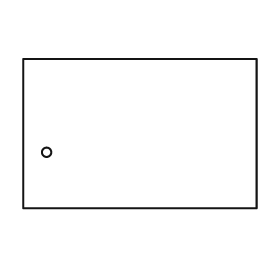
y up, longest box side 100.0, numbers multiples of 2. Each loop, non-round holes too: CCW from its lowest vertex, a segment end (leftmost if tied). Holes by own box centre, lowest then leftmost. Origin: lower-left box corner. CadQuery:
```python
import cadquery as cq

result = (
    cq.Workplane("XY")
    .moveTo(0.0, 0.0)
    .lineTo(100.0, 0.0)
    .lineTo(100.0, 64.0)
    .lineTo(0.0, 64.0)
    .close()
    .moveTo(10.0, 24.0)
    .circle(2.0)
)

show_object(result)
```